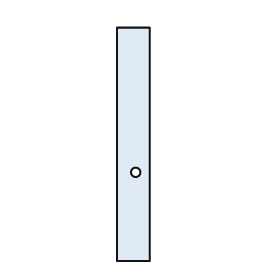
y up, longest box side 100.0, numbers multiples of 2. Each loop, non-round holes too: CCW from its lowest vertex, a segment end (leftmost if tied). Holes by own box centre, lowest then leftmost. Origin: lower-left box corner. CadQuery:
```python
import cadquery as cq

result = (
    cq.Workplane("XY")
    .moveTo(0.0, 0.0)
    .lineTo(14.0, 0.0)
    .lineTo(14.0, 100.0)
    .lineTo(0.0, 100.0)
    .close()
    .moveTo(8.0, 38.0)
    .circle(2.0)
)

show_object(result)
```